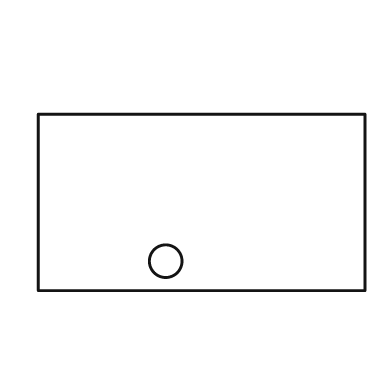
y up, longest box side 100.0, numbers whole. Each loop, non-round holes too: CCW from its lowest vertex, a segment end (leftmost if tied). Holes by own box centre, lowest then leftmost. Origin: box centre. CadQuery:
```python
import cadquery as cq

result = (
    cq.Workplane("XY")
    .moveTo(-50.0, -27.0)
    .lineTo(50.0, -27.0)
    .lineTo(50.0, 27.0)
    .lineTo(-50.0, 27.0)
    .close()
    .moveTo(-11.0, -18.0)
    .circle(5.0)
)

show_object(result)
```